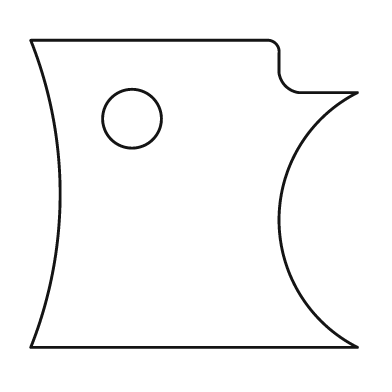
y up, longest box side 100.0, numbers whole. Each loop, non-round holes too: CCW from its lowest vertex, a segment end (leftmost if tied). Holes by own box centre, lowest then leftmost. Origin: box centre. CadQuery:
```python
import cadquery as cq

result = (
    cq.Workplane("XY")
    .moveTo(-50.0, -47.0)
    .lineTo(50.0, -47.0)
    .threePointArc((26.0, -8.0), (50.0, 31.0))
    .lineTo(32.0, 31.0)
    .threePointArc((28.0, 33.0), (26.0, 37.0))
    .lineTo(26.0, 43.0)
    .threePointArc((25.0, 46.0), (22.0, 47.0))
    .lineTo(-50.0, 47.0)
    .threePointArc((-41.0, 0.0), (-50.0, -47.0))
    .close()
    .moveTo(-19.0, 23.0)
    .circle(9.0)
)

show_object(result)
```